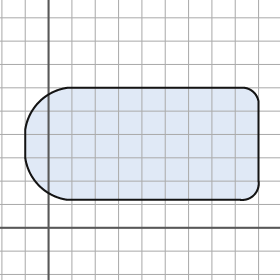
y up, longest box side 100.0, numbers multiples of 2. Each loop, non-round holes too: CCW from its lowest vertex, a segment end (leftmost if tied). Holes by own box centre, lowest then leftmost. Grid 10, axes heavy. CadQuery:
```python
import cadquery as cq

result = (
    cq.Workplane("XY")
    .moveTo(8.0, 12.0)
    .lineTo(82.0, 12.0)
    .threePointArc((88.0, 14.0), (90.0, 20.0))
    .lineTo(90.0, 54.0)
    .threePointArc((88.0, 58.0), (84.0, 60.0))
    .lineTo(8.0, 60.0)
    .threePointArc((-4.0, 54.0), (-10.0, 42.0))
    .lineTo(-10.0, 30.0)
    .threePointArc((-4.0, 18.0), (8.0, 12.0))
    .close()
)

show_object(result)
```